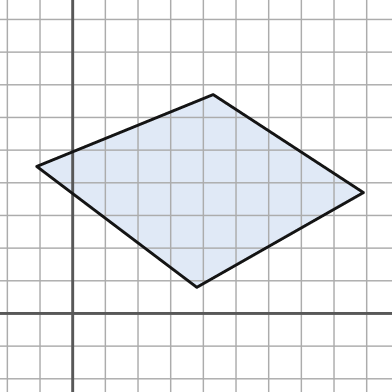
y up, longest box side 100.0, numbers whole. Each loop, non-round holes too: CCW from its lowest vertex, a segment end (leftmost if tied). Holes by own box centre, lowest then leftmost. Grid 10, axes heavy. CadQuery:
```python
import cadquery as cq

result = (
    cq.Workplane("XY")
    .moveTo(38.0, 8.0)
    .lineTo(89.0, 37.0)
    .lineTo(43.0, 67.0)
    .lineTo(-11.0, 45.0)
    .close()
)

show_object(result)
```